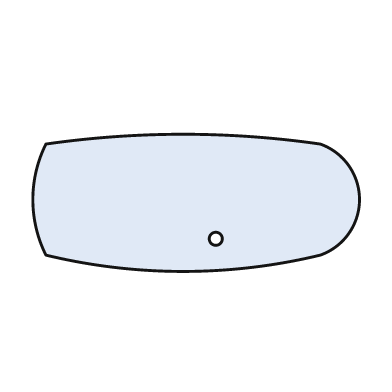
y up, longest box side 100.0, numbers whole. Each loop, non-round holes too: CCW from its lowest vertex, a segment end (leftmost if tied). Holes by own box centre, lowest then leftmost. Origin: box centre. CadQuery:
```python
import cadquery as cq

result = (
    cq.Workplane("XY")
    .moveTo(-46.0, -16.0)
    .threePointArc((-4.0, -21.0), (38.0, -16.0))
    .threePointArc((50.0, 1.0), (38.0, 18.0))
    .threePointArc((-4.0, 21.0), (-46.0, 18.0))
    .threePointArc((-50.0, 1.0), (-46.0, -16.0))
    .close()
    .moveTo(6.0, -11.0)
    .circle(2.0)
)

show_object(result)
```